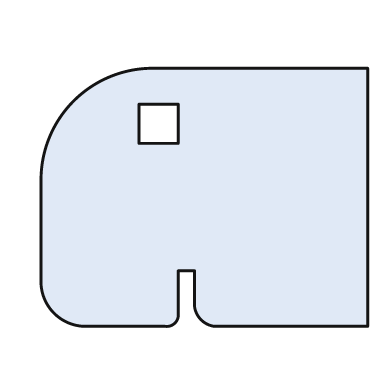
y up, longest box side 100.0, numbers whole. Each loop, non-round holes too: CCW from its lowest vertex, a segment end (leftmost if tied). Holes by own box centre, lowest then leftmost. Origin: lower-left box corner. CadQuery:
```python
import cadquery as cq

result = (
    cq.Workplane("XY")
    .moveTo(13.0, 0.0)
    .lineTo(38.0, 0.0)
    .threePointArc((41.0, 1.0), (42.0, 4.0))
    .lineTo(42.0, 17.0)
    .lineTo(47.0, 17.0)
    .lineTo(47.0, 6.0)
    .threePointArc((49.0, 2.0), (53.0, 0.0))
    .lineTo(100.0, 0.0)
    .lineTo(100.0, 79.0)
    .lineTo(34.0, 79.0)
    .threePointArc((10.0, 69.0), (0.0, 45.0))
    .lineTo(0.0, 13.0)
    .threePointArc((4.0, 4.0), (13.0, 0.0))
    .close()
    .moveTo(30.0, 56.0)
    .lineTo(42.0, 56.0)
    .lineTo(42.0, 68.0)
    .lineTo(30.0, 68.0)
    .close()
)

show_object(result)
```